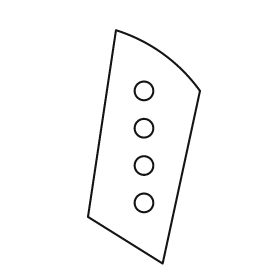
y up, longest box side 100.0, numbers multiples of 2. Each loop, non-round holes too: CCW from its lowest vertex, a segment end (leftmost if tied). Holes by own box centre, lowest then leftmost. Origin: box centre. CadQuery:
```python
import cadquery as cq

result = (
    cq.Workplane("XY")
    .moveTo(8.0, -50.0)
    .lineTo(24.0, 24.0)
    .threePointArc((8.0, 40.0), (-12.0, 50.0))
    .lineTo(-24.0, -30.0)
    .close()
    .moveTo(0.0, -24.0)
    .circle(4.0)
    .moveTo(0.0, -8.0)
    .circle(4.0)
    .moveTo(0.0, 8.0)
    .circle(4.0)
    .moveTo(0.0, 24.0)
    .circle(4.0)
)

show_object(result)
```